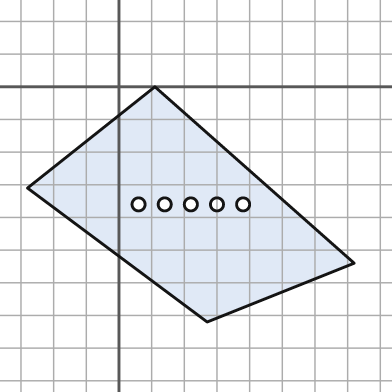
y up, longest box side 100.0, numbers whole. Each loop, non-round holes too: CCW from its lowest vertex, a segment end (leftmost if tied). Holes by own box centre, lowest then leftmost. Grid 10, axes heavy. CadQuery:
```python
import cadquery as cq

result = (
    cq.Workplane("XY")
    .moveTo(27.0, -72.0)
    .lineTo(72.0, -54.0)
    .lineTo(11.0, 0.0)
    .lineTo(-28.0, -31.0)
    .close()
    .moveTo(6.0, -36.0)
    .circle(2.0)
    .moveTo(14.0, -36.0)
    .circle(2.0)
    .moveTo(22.0, -36.0)
    .circle(2.0)
    .moveTo(30.0, -36.0)
    .circle(2.0)
    .moveTo(38.0, -36.0)
    .circle(2.0)
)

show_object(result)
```